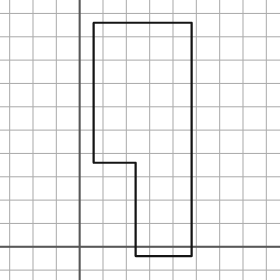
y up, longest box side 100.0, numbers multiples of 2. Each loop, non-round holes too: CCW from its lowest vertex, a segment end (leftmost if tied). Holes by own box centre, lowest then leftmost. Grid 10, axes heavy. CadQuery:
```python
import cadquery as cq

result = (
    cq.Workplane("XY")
    .moveTo(24.0, -4.0)
    .lineTo(48.0, -4.0)
    .lineTo(48.0, 96.0)
    .lineTo(6.0, 96.0)
    .lineTo(6.0, 36.0)
    .lineTo(24.0, 36.0)
    .close()
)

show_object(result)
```